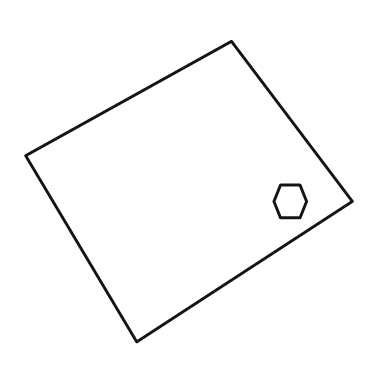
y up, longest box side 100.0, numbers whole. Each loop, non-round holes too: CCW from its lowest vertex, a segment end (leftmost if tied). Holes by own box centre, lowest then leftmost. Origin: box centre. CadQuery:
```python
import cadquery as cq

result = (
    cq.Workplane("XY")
    .moveTo(-16.0, -46.0)
    .lineTo(50.0, -3.0)
    .lineTo(13.0, 46.0)
    .lineTo(-50.0, 11.0)
    .close()
    .moveTo(28.0, -8.0)
    .lineTo(34.0, -8.0)
    .lineTo(36.0, -3.0)
    .lineTo(34.0, 2.0)
    .lineTo(28.0, 2.0)
    .lineTo(26.0, -3.0)
    .close()
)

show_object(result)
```